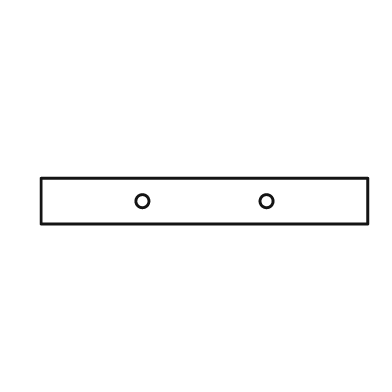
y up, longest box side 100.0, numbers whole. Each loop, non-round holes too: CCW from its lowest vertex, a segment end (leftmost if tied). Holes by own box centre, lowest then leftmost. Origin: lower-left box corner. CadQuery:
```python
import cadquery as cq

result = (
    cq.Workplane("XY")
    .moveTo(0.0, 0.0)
    .lineTo(100.0, 0.0)
    .lineTo(100.0, 14.0)
    .lineTo(0.0, 14.0)
    .close()
    .moveTo(31.0, 7.0)
    .circle(2.0)
    .moveTo(69.0, 7.0)
    .circle(2.0)
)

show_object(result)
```